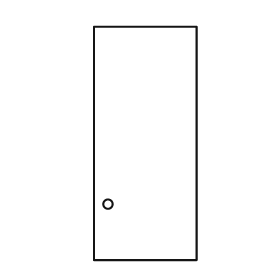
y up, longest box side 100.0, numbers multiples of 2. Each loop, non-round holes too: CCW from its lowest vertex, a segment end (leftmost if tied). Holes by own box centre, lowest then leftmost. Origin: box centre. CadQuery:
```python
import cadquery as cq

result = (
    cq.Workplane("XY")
    .moveTo(-22.0, -50.0)
    .lineTo(22.0, -50.0)
    .lineTo(22.0, 50.0)
    .lineTo(-22.0, 50.0)
    .close()
    .moveTo(-16.0, -26.0)
    .circle(2.0)
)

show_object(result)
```